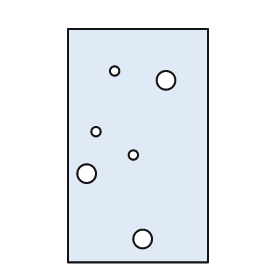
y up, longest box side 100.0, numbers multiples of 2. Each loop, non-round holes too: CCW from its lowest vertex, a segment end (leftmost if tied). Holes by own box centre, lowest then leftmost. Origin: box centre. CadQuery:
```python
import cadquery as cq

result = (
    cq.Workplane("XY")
    .moveTo(-30.0, -50.0)
    .lineTo(30.0, -50.0)
    .lineTo(30.0, 50.0)
    .lineTo(-30.0, 50.0)
    .close()
    .moveTo(2.0, -40.0)
    .circle(4.0)
    .moveTo(-22.0, -12.0)
    .circle(4.0)
    .moveTo(-2.0, -4.0)
    .circle(2.0)
    .moveTo(-18.0, 6.0)
    .circle(2.0)
    .moveTo(12.0, 28.0)
    .circle(4.0)
    .moveTo(-10.0, 32.0)
    .circle(2.0)
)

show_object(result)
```